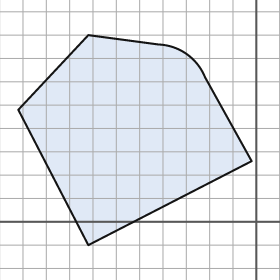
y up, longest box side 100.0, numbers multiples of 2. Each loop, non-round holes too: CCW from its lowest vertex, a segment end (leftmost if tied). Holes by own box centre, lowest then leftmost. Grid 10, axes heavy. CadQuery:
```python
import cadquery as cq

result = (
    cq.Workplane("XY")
    .moveTo(-72.0, -10.0)
    .lineTo(-2.0, 26.0)
    .lineTo(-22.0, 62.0)
    .threePointArc((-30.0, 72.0), (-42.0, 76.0))
    .lineTo(-72.0, 80.0)
    .lineTo(-102.0, 48.0)
    .close()
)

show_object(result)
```